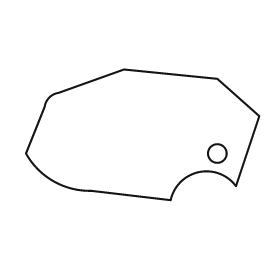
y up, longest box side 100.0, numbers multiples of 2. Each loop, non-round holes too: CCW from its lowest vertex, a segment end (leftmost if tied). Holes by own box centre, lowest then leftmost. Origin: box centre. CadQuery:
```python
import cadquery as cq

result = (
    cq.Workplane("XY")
    .moveTo(12.0, -28.0)
    .threePointArc((24.0, -16.0), (40.0, -22.0))
    .lineTo(50.0, 8.0)
    .lineTo(32.0, 24.0)
    .lineTo(-8.0, 28.0)
    .lineTo(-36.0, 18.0)
    .threePointArc((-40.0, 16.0), (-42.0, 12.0))
    .lineTo(-50.0, -8.0)
    .threePointArc((-38.0, -20.0), (-22.0, -24.0))
    .close()
    .moveTo(32.0, -8.0)
    .circle(4.0)
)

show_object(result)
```